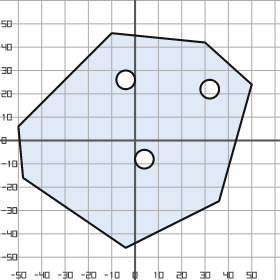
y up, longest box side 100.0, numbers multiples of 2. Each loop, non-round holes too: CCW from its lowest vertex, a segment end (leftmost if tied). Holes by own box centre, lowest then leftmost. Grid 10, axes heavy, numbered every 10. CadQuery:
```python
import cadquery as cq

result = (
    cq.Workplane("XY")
    .moveTo(-4.0, -46.0)
    .lineTo(36.0, -26.0)
    .lineTo(50.0, 24.0)
    .lineTo(30.0, 42.0)
    .lineTo(-10.0, 46.0)
    .lineTo(-50.0, 6.0)
    .lineTo(-48.0, -16.0)
    .close()
    .moveTo(4.0, -8.0)
    .circle(4.0)
    .moveTo(32.0, 22.0)
    .circle(4.0)
    .moveTo(-4.0, 26.0)
    .circle(4.0)
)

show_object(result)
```